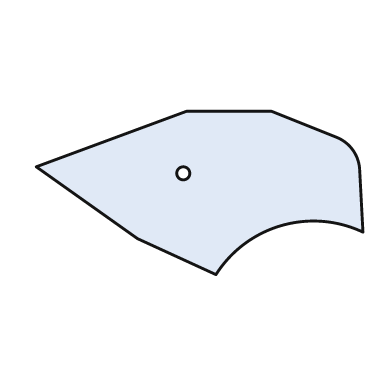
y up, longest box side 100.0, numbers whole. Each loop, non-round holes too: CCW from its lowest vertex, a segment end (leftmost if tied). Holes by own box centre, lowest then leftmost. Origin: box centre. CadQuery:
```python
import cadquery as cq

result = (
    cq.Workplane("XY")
    .moveTo(5.0, -25.0)
    .threePointArc((25.0, -10.0), (50.0, -12.0))
    .lineTo(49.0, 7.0)
    .threePointArc((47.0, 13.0), (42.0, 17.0))
    .lineTo(22.0, 25.0)
    .lineTo(-4.0, 25.0)
    .lineTo(-50.0, 8.0)
    .lineTo(-19.0, -14.0)
    .close()
    .moveTo(-5.0, 6.0)
    .circle(2.0)
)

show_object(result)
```